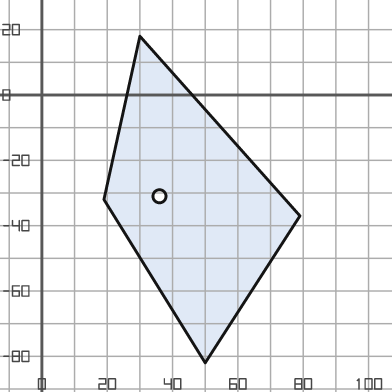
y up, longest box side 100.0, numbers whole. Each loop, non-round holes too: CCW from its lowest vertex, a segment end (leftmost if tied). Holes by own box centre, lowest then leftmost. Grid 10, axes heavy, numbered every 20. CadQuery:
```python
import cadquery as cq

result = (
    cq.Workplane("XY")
    .moveTo(50.0, -82.0)
    .lineTo(79.0, -37.0)
    .lineTo(30.0, 18.0)
    .lineTo(19.0, -32.0)
    .close()
    .moveTo(36.0, -31.0)
    .circle(2.0)
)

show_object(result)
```